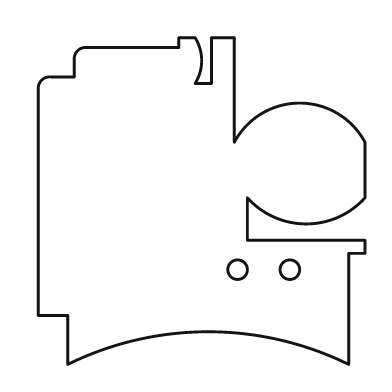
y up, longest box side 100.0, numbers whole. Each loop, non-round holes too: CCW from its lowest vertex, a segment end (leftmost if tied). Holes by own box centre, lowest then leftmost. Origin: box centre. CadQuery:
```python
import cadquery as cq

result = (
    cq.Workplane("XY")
    .moveTo(-41.0, -50.0)
    .threePointArc((2.0, -40.0), (45.0, -50.0))
    .lineTo(45.0, -16.0)
    .lineTo(50.0, -16.0)
    .lineTo(50.0, -12.0)
    .lineTo(14.0, -12.0)
    .lineTo(14.0, 1.0)
    .threePointArc((32.0, -7.0), (50.0, 1.0))
    .lineTo(50.0, 18.0)
    .threePointArc((30.0, 30.0), (10.0, 18.0))
    .lineTo(10.0, 50.0)
    .lineTo(3.0, 50.0)
    .lineTo(3.0, 36.0)
    .lineTo(-2.0, 36.0)
    .threePointArc((0.0, 43.0), (-2.0, 50.0))
    .lineTo(-7.0, 50.0)
    .lineTo(-7.0, 47.0)
    .lineTo(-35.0, 47.0)
    .threePointArc((-38.0, 46.0), (-39.0, 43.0))
    .lineTo(-39.0, 38.0)
    .lineTo(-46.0, 38.0)
    .threePointArc((-49.0, 37.0), (-50.0, 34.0))
    .lineTo(-50.0, -35.0)
    .lineTo(-41.0, -35.0)
    .close()
    .moveTo(11.0, -21.0)
    .circle(3.0)
    .moveTo(27.0, -21.0)
    .circle(3.0)
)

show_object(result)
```